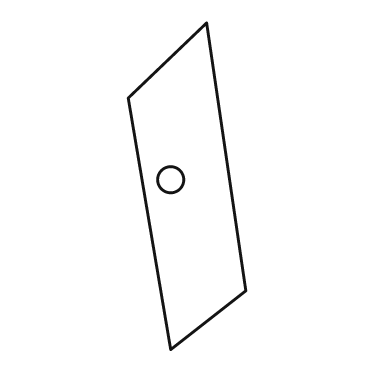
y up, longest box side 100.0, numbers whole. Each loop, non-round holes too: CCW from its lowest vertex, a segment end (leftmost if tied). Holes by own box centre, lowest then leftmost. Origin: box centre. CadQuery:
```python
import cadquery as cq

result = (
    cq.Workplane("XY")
    .moveTo(-5.0, -50.0)
    .lineTo(18.0, -32.0)
    .lineTo(6.0, 50.0)
    .lineTo(-18.0, 27.0)
    .close()
    .moveTo(-5.0, 2.0)
    .circle(4.0)
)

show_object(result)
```